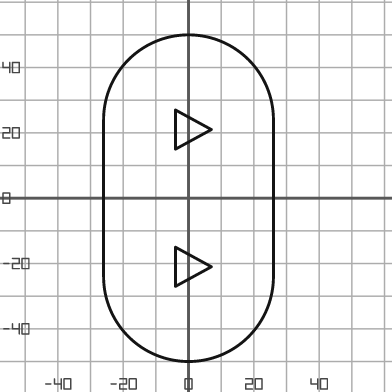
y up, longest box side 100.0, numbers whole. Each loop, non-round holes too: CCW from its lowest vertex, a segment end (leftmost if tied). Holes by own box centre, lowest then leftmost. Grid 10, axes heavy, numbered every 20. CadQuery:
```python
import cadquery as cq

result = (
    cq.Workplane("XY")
    .moveTo(-26.0, -24.0)
    .threePointArc((0.0, -50.0), (26.0, -24.0))
    .lineTo(26.0, 24.0)
    .threePointArc((0.0, 50.0), (-26.0, 24.0))
    .close()
    .moveTo(-4.0, -27.0)
    .lineTo(7.0, -21.0)
    .lineTo(-4.0, -15.0)
    .close()
    .moveTo(-4.0, 15.0)
    .lineTo(7.0, 21.0)
    .lineTo(-4.0, 27.0)
    .close()
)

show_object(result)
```